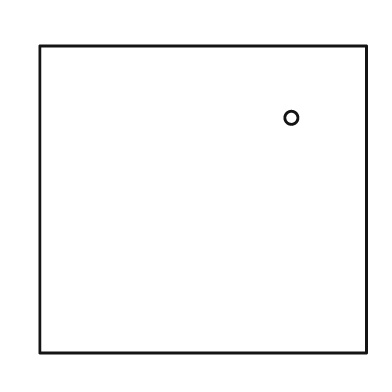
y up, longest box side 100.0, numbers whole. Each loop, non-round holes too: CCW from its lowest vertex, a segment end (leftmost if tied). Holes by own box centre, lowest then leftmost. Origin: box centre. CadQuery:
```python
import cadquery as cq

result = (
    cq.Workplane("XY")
    .moveTo(-50.0, -47.0)
    .lineTo(50.0, -47.0)
    .lineTo(50.0, 47.0)
    .lineTo(-50.0, 47.0)
    .close()
    .moveTo(27.0, 25.0)
    .circle(2.0)
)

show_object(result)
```